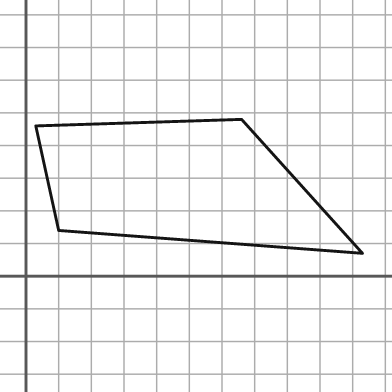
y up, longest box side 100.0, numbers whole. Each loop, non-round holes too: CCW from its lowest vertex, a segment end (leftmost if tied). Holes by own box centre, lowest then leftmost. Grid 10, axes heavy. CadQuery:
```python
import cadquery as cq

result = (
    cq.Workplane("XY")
    .moveTo(103.0, 7.0)
    .lineTo(66.0, 48.0)
    .lineTo(3.0, 46.0)
    .lineTo(10.0, 14.0)
    .close()
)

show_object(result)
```